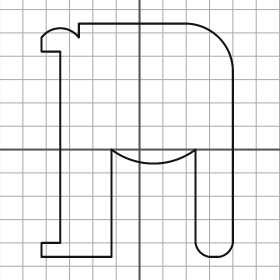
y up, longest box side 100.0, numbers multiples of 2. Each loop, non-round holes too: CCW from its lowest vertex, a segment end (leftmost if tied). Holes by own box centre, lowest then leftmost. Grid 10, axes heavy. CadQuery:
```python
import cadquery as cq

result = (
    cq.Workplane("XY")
    .moveTo(-42.0, -46.0)
    .lineTo(-12.0, -46.0)
    .lineTo(-12.0, 0.0)
    .threePointArc((6.0, -6.0), (24.0, 0.0))
    .lineTo(24.0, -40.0)
    .threePointArc((26.0, -44.0), (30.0, -46.0))
    .lineTo(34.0, -46.0)
    .threePointArc((38.0, -44.0), (40.0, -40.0))
    .lineTo(40.0, 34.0)
    .threePointArc((34.0, 48.0), (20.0, 54.0))
    .lineTo(-26.0, 54.0)
    .lineTo(-26.0, 48.0)
    .threePointArc((-34.0, 52.0), (-42.0, 48.0))
    .lineTo(-42.0, 42.0)
    .lineTo(-34.0, 42.0)
    .lineTo(-34.0, -40.0)
    .lineTo(-42.0, -40.0)
    .close()
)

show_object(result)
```